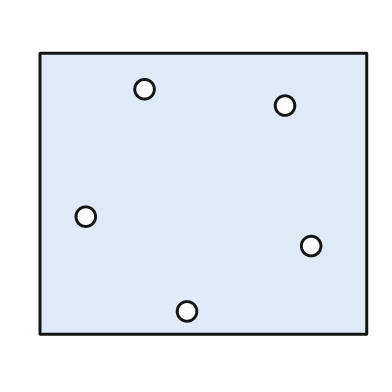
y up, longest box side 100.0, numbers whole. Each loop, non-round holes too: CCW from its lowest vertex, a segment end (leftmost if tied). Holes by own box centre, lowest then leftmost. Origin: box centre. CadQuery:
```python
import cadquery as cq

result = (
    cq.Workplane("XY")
    .moveTo(-50.0, -43.0)
    .lineTo(50.0, -43.0)
    .lineTo(50.0, 43.0)
    .lineTo(-50.0, 43.0)
    .close()
    .moveTo(-5.0, -36.0)
    .circle(3.0)
    .moveTo(33.0, -16.0)
    .circle(3.0)
    .moveTo(-36.0, -7.0)
    .circle(3.0)
    .moveTo(25.0, 27.0)
    .circle(3.0)
    .moveTo(-18.0, 32.0)
    .circle(3.0)
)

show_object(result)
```